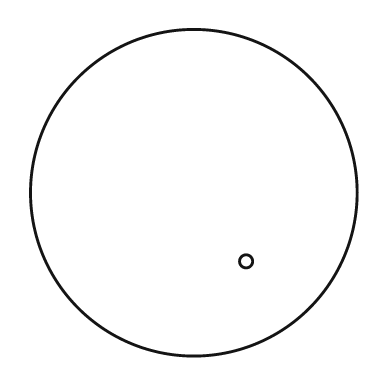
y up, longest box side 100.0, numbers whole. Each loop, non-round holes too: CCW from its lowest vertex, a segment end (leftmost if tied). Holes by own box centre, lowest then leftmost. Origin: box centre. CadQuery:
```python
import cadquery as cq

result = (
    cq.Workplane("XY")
    .moveTo(0.0, 0.0)
    .circle(50.0)
    .moveTo(16.0, -21.0)
    .circle(2.0)
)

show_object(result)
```